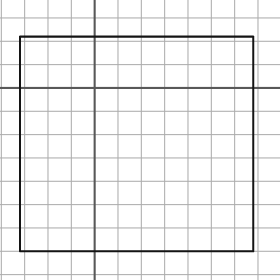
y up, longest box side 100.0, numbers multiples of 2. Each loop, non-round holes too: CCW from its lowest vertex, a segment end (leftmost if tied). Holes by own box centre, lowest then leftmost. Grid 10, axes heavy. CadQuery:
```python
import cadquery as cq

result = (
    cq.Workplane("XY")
    .moveTo(-32.0, -70.0)
    .lineTo(68.0, -70.0)
    .lineTo(68.0, 22.0)
    .lineTo(-32.0, 22.0)
    .close()
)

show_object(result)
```